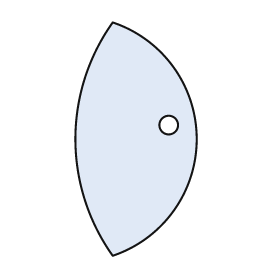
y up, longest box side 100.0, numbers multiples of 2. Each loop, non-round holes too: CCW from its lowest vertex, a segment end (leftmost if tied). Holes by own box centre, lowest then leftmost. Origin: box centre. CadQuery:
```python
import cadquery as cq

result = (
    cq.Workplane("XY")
    .moveTo(-10.0, -50.0)
    .threePointArc((26.0, 0.0), (-10.0, 50.0))
    .threePointArc((-26.0, 0.0), (-10.0, -50.0))
    .close()
    .moveTo(14.0, 6.0)
    .circle(4.0)
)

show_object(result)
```